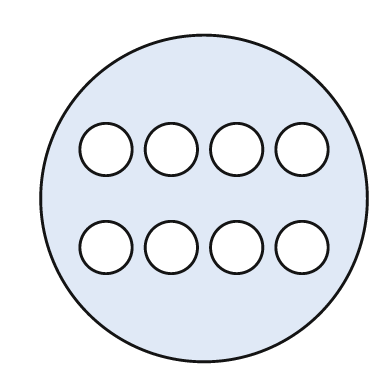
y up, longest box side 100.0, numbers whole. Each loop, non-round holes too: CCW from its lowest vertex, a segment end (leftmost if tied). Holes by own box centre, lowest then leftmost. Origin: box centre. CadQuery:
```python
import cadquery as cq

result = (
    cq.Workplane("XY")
    .moveTo(0.0, 0.0)
    .circle(50.0)
    .moveTo(-30.0, -15.0)
    .circle(8.0)
    .moveTo(-10.0, -15.0)
    .circle(8.0)
    .moveTo(10.0, -15.0)
    .circle(8.0)
    .moveTo(30.0, -15.0)
    .circle(8.0)
    .moveTo(-30.0, 15.0)
    .circle(8.0)
    .moveTo(-10.0, 15.0)
    .circle(8.0)
    .moveTo(10.0, 15.0)
    .circle(8.0)
    .moveTo(30.0, 15.0)
    .circle(8.0)
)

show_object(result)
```